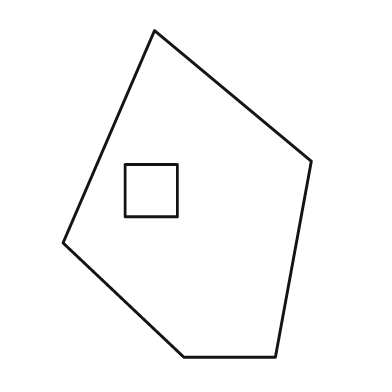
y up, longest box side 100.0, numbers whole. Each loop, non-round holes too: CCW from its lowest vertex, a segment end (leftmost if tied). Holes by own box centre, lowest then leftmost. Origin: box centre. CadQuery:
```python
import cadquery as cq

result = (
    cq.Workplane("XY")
    .moveTo(-1.0, -50.0)
    .lineTo(27.0, -50.0)
    .lineTo(38.0, 10.0)
    .lineTo(-10.0, 50.0)
    .lineTo(-38.0, -15.0)
    .close()
    .moveTo(-19.0, -7.0)
    .lineTo(-3.0, -7.0)
    .lineTo(-3.0, 9.0)
    .lineTo(-19.0, 9.0)
    .close()
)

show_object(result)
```